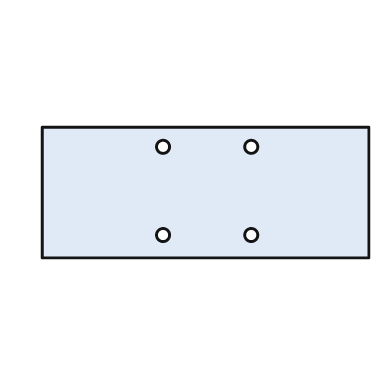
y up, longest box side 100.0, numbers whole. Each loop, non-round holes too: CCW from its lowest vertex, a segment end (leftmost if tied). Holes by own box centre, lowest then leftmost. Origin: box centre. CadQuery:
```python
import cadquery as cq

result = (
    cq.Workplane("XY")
    .moveTo(-50.0, -20.0)
    .lineTo(50.0, -20.0)
    .lineTo(50.0, 20.0)
    .lineTo(-50.0, 20.0)
    .close()
    .moveTo(-13.0, -13.0)
    .circle(2.0)
    .moveTo(14.0, -13.0)
    .circle(2.0)
    .moveTo(-13.0, 14.0)
    .circle(2.0)
    .moveTo(14.0, 14.0)
    .circle(2.0)
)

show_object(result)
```